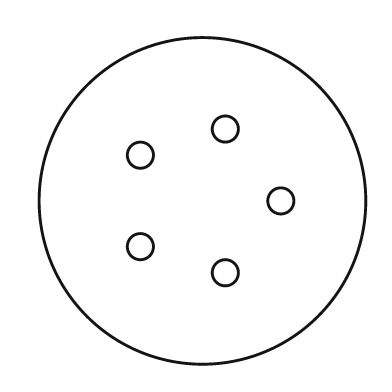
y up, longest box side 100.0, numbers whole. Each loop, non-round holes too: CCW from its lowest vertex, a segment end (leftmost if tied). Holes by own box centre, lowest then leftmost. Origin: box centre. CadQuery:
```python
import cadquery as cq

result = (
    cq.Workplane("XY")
    .moveTo(0.0, 0.0)
    .circle(50.0)
    .moveTo(7.0, -22.0)
    .circle(4.0)
    .moveTo(-19.0, -14.0)
    .circle(4.0)
    .moveTo(24.0, 0.0)
    .circle(4.0)
    .moveTo(-19.0, 14.0)
    .circle(4.0)
    .moveTo(7.0, 22.0)
    .circle(4.0)
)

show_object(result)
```